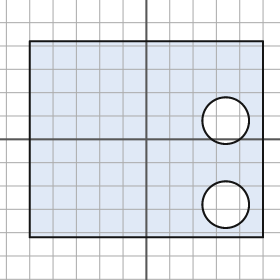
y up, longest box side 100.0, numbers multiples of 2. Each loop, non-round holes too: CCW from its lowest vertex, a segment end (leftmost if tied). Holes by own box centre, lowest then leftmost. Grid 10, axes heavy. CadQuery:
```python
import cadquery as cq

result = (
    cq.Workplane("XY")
    .moveTo(-50.0, -42.0)
    .lineTo(50.0, -42.0)
    .lineTo(50.0, 42.0)
    .lineTo(-50.0, 42.0)
    .close()
    .moveTo(34.0, -28.0)
    .circle(10.0)
    .moveTo(34.0, 8.0)
    .circle(10.0)
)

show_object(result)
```